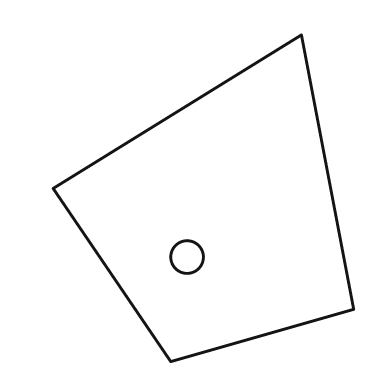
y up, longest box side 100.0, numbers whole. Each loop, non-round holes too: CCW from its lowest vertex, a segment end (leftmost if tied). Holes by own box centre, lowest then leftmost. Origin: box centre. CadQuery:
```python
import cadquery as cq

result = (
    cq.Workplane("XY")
    .moveTo(-10.0, -50.0)
    .lineTo(46.0, -34.0)
    .lineTo(30.0, 50.0)
    .lineTo(-46.0, 3.0)
    .close()
    .moveTo(-5.0, -18.0)
    .circle(5.0)
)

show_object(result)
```